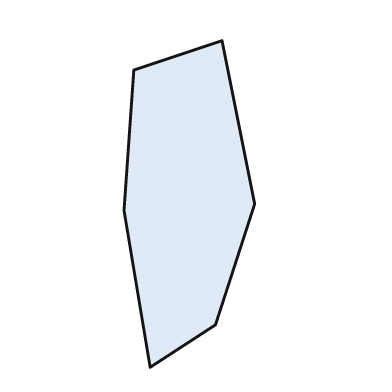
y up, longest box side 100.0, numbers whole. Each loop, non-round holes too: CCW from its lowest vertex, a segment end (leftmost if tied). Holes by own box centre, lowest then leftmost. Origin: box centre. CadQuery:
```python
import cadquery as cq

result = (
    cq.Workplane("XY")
    .moveTo(-12.0, -50.0)
    .lineTo(8.0, -37.0)
    .lineTo(20.0, 0.0)
    .lineTo(10.0, 50.0)
    .lineTo(-17.0, 41.0)
    .lineTo(-20.0, -2.0)
    .close()
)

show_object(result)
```